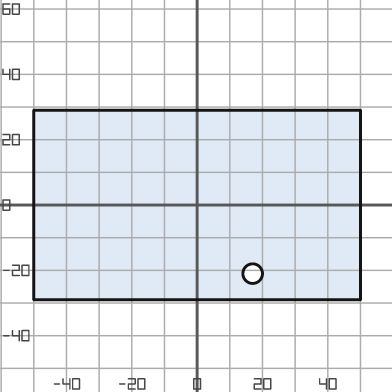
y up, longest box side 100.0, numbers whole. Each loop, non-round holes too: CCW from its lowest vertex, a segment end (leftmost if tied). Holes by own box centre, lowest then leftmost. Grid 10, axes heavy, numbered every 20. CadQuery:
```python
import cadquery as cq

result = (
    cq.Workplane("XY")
    .moveTo(-50.0, -29.0)
    .lineTo(50.0, -29.0)
    .lineTo(50.0, 29.0)
    .lineTo(-50.0, 29.0)
    .close()
    .moveTo(17.0, -21.0)
    .circle(3.0)
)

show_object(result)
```